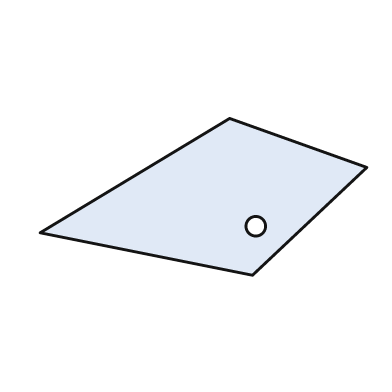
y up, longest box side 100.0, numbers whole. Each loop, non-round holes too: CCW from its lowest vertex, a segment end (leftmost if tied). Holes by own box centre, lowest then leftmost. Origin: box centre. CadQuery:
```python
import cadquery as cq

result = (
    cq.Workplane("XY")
    .moveTo(15.0, -24.0)
    .lineTo(50.0, 9.0)
    .lineTo(8.0, 24.0)
    .lineTo(-50.0, -11.0)
    .close()
    .moveTo(16.0, -9.0)
    .circle(3.0)
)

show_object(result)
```